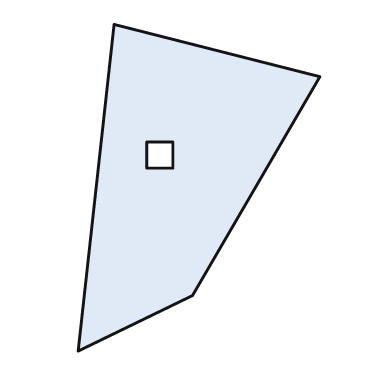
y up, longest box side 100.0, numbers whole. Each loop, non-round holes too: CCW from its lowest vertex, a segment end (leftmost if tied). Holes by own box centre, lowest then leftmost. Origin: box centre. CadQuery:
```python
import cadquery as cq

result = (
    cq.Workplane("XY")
    .moveTo(-37.0, -50.0)
    .lineTo(-2.0, -33.0)
    .lineTo(37.0, 34.0)
    .lineTo(-26.0, 50.0)
    .close()
    .moveTo(-16.0, 6.0)
    .lineTo(-8.0, 6.0)
    .lineTo(-8.0, 14.0)
    .lineTo(-16.0, 14.0)
    .close()
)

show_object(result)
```